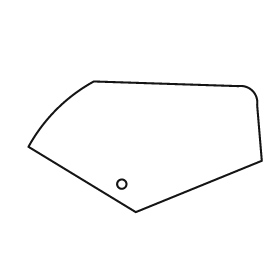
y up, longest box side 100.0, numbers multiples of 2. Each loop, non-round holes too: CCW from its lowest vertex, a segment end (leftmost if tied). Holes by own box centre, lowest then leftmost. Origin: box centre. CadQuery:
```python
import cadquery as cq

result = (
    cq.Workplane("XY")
    .moveTo(-4.0, -28.0)
    .lineTo(50.0, -6.0)
    .lineTo(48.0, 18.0)
    .threePointArc((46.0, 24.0), (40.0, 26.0))
    .lineTo(-22.0, 28.0)
    .threePointArc((-38.0, 16.0), (-50.0, 0.0))
    .close()
    .moveTo(-10.0, -16.0)
    .circle(2.0)
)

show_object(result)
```